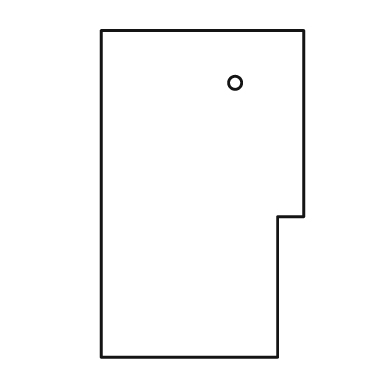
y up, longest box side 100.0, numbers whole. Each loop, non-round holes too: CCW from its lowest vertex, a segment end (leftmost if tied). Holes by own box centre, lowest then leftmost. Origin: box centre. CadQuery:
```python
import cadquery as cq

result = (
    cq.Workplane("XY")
    .moveTo(-31.0, -50.0)
    .lineTo(23.0, -50.0)
    .lineTo(23.0, -7.0)
    .lineTo(31.0, -7.0)
    .lineTo(31.0, 50.0)
    .lineTo(-31.0, 50.0)
    .close()
    .moveTo(10.0, 34.0)
    .circle(2.0)
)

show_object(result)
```